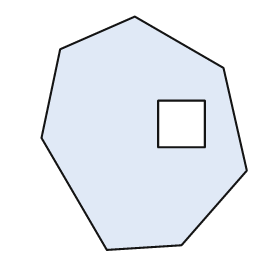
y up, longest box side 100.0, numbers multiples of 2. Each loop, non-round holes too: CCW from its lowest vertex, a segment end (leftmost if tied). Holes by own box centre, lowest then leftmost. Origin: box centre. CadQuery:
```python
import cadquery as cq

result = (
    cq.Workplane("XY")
    .moveTo(-16.0, -50.0)
    .lineTo(16.0, -48.0)
    .lineTo(44.0, -16.0)
    .lineTo(34.0, 28.0)
    .lineTo(-4.0, 50.0)
    .lineTo(-36.0, 36.0)
    .lineTo(-44.0, -2.0)
    .close()
    .moveTo(6.0, -6.0)
    .lineTo(26.0, -6.0)
    .lineTo(26.0, 14.0)
    .lineTo(6.0, 14.0)
    .close()
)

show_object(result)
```